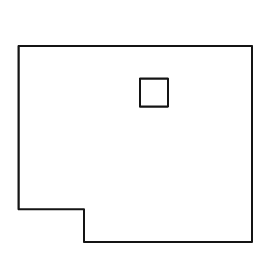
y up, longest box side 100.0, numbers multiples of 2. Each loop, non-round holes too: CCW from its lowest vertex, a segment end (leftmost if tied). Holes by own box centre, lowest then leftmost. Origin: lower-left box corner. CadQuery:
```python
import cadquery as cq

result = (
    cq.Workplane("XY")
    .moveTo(28.0, 0.0)
    .lineTo(100.0, 0.0)
    .lineTo(100.0, 84.0)
    .lineTo(0.0, 84.0)
    .lineTo(0.0, 14.0)
    .lineTo(28.0, 14.0)
    .close()
    .moveTo(52.0, 58.0)
    .lineTo(64.0, 58.0)
    .lineTo(64.0, 70.0)
    .lineTo(52.0, 70.0)
    .close()
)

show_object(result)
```